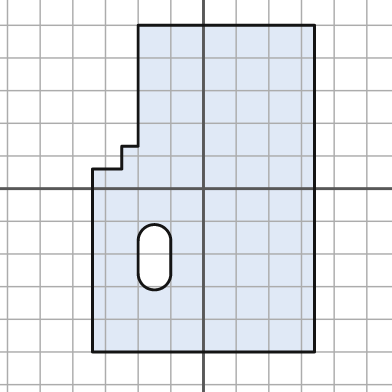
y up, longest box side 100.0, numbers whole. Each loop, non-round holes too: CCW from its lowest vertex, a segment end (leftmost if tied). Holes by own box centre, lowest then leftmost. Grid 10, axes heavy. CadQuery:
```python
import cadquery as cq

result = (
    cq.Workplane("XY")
    .moveTo(-34.0, -50.0)
    .lineTo(34.0, -50.0)
    .lineTo(34.0, 50.0)
    .lineTo(-20.0, 50.0)
    .lineTo(-20.0, 13.0)
    .lineTo(-25.0, 13.0)
    .lineTo(-25.0, 6.0)
    .lineTo(-34.0, 6.0)
    .close()
    .moveTo(-20.0, -26.0)
    .threePointArc((-15.0, -31.0), (-10.0, -26.0))
    .lineTo(-10.0, -16.0)
    .threePointArc((-15.0, -11.0), (-20.0, -16.0))
    .close()
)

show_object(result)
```